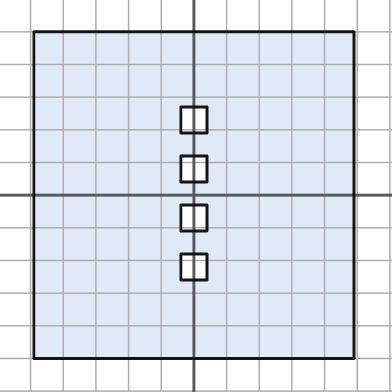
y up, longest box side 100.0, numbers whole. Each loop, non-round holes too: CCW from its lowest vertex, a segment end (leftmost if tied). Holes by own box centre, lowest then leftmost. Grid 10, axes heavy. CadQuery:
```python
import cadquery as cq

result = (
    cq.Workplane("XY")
    .moveTo(-49.0, -50.0)
    .lineTo(49.0, -50.0)
    .lineTo(49.0, 50.0)
    .lineTo(-49.0, 50.0)
    .close()
    .moveTo(-4.0, -26.0)
    .lineTo(4.0, -26.0)
    .lineTo(4.0, -18.0)
    .lineTo(-4.0, -18.0)
    .close()
    .moveTo(-4.0, -11.0)
    .lineTo(4.0, -11.0)
    .lineTo(4.0, -3.0)
    .lineTo(-4.0, -3.0)
    .close()
    .moveTo(-4.0, 4.0)
    .lineTo(4.0, 4.0)
    .lineTo(4.0, 12.0)
    .lineTo(-4.0, 12.0)
    .close()
    .moveTo(-4.0, 19.0)
    .lineTo(4.0, 19.0)
    .lineTo(4.0, 27.0)
    .lineTo(-4.0, 27.0)
    .close()
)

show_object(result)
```